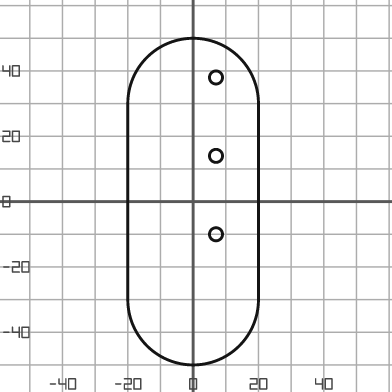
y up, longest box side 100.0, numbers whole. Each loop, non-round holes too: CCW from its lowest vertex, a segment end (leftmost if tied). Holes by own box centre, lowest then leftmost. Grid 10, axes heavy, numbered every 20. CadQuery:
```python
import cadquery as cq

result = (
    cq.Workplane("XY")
    .moveTo(-20.0, -30.0)
    .threePointArc((0.0, -50.0), (20.0, -30.0))
    .lineTo(20.0, 30.0)
    .threePointArc((0.0, 50.0), (-20.0, 30.0))
    .close()
    .moveTo(7.0, -10.0)
    .circle(2.0)
    .moveTo(7.0, 14.0)
    .circle(2.0)
    .moveTo(7.0, 38.0)
    .circle(2.0)
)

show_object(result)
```